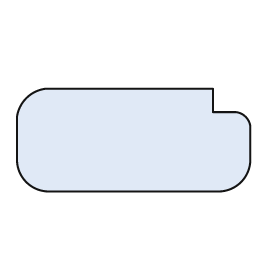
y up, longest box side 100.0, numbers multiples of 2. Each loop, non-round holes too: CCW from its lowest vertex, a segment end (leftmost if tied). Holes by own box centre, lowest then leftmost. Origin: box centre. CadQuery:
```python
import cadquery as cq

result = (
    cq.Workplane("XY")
    .moveTo(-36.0, -22.0)
    .lineTo(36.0, -22.0)
    .threePointArc((46.0, -18.0), (50.0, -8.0))
    .lineTo(50.0, 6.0)
    .threePointArc((48.0, 10.0), (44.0, 12.0))
    .lineTo(34.0, 12.0)
    .lineTo(34.0, 22.0)
    .lineTo(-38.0, 22.0)
    .threePointArc((-46.0, 18.0), (-50.0, 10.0))
    .lineTo(-50.0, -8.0)
    .threePointArc((-46.0, -18.0), (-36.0, -22.0))
    .close()
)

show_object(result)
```